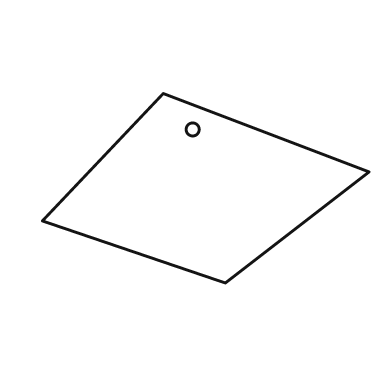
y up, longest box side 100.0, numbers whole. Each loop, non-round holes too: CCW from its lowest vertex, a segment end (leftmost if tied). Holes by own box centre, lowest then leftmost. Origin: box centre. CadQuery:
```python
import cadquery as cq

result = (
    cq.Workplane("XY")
    .moveTo(6.0, -29.0)
    .lineTo(50.0, 5.0)
    .lineTo(-13.0, 29.0)
    .lineTo(-50.0, -10.0)
    .close()
    .moveTo(-4.0, 18.0)
    .circle(2.0)
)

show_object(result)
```